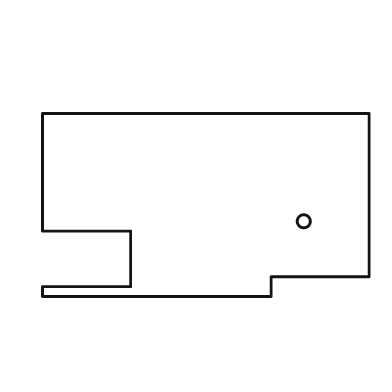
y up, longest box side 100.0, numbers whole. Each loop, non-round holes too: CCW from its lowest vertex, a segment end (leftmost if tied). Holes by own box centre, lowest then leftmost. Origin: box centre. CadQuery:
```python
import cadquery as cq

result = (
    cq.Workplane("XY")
    .moveTo(-50.0, -28.0)
    .lineTo(20.0, -28.0)
    .lineTo(20.0, -22.0)
    .lineTo(50.0, -22.0)
    .lineTo(50.0, 28.0)
    .lineTo(-50.0, 28.0)
    .lineTo(-50.0, -8.0)
    .lineTo(-23.0, -8.0)
    .lineTo(-23.0, -25.0)
    .lineTo(-50.0, -25.0)
    .close()
    .moveTo(30.0, -5.0)
    .circle(2.0)
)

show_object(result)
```